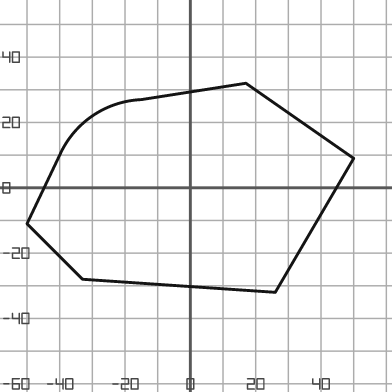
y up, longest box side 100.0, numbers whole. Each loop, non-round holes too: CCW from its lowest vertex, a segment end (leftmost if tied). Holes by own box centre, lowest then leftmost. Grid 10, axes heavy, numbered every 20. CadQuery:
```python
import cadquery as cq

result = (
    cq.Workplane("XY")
    .moveTo(26.0, -32.0)
    .lineTo(50.0, 9.0)
    .lineTo(17.0, 32.0)
    .lineTo(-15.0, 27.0)
    .threePointArc((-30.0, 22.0), (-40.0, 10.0))
    .lineTo(-50.0, -11.0)
    .lineTo(-33.0, -28.0)
    .close()
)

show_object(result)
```